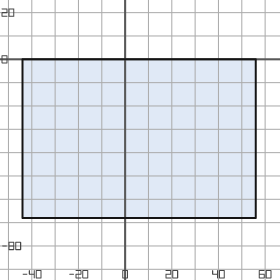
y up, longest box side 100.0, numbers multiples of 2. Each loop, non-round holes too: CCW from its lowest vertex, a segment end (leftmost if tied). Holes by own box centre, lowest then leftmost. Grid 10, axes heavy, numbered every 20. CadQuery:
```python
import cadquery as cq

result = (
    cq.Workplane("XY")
    .moveTo(-44.0, -68.0)
    .lineTo(56.0, -68.0)
    .lineTo(56.0, 0.0)
    .lineTo(-44.0, 0.0)
    .close()
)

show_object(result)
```